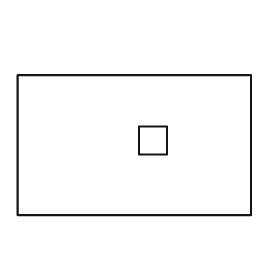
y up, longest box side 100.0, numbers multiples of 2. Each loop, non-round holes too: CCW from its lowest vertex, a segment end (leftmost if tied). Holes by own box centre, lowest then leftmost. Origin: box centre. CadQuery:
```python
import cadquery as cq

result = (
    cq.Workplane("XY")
    .moveTo(-50.0, -30.0)
    .lineTo(50.0, -30.0)
    .lineTo(50.0, 30.0)
    .lineTo(-50.0, 30.0)
    .close()
    .moveTo(2.0, -4.0)
    .lineTo(14.0, -4.0)
    .lineTo(14.0, 8.0)
    .lineTo(2.0, 8.0)
    .close()
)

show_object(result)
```